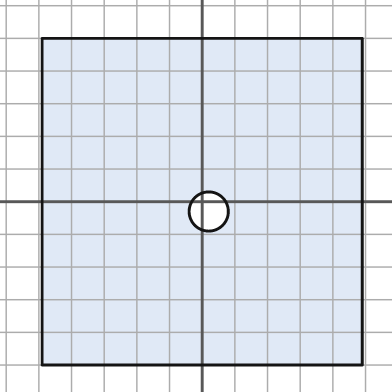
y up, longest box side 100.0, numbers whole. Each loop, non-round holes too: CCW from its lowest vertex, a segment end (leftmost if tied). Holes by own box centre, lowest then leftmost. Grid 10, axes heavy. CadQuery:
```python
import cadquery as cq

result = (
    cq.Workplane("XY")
    .moveTo(-49.0, -50.0)
    .lineTo(49.0, -50.0)
    .lineTo(49.0, 50.0)
    .lineTo(-49.0, 50.0)
    .close()
    .moveTo(2.0, -3.0)
    .circle(6.0)
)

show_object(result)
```